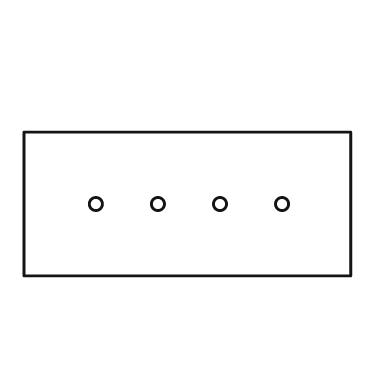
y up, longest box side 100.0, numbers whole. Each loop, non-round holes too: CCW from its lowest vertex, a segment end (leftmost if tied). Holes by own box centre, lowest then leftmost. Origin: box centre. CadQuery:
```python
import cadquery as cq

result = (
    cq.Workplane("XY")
    .moveTo(-50.0, -22.0)
    .lineTo(50.0, -22.0)
    .lineTo(50.0, 22.0)
    .lineTo(-50.0, 22.0)
    .close()
    .moveTo(-28.0, 0.0)
    .circle(2.0)
    .moveTo(-9.0, 0.0)
    .circle(2.0)
    .moveTo(10.0, 0.0)
    .circle(2.0)
    .moveTo(29.0, 0.0)
    .circle(2.0)
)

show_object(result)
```